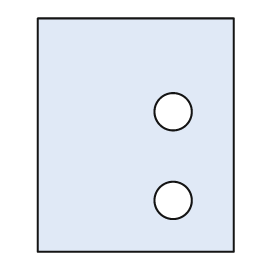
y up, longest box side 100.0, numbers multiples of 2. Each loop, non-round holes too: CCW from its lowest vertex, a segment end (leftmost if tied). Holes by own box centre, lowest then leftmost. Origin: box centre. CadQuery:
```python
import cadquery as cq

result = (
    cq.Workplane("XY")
    .moveTo(-42.0, -50.0)
    .lineTo(42.0, -50.0)
    .lineTo(42.0, 50.0)
    .lineTo(-42.0, 50.0)
    .close()
    .moveTo(16.0, -28.0)
    .circle(8.0)
    .moveTo(16.0, 10.0)
    .circle(8.0)
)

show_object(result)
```